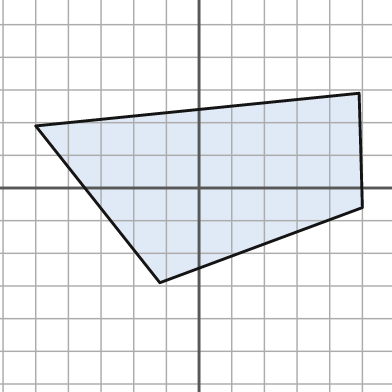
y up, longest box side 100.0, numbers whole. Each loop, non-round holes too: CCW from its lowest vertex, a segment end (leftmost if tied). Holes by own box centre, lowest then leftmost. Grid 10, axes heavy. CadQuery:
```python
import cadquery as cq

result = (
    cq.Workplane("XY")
    .moveTo(-12.0, -29.0)
    .lineTo(50.0, -6.0)
    .lineTo(49.0, 29.0)
    .lineTo(-50.0, 19.0)
    .close()
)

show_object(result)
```